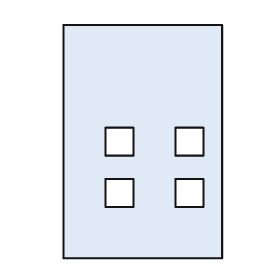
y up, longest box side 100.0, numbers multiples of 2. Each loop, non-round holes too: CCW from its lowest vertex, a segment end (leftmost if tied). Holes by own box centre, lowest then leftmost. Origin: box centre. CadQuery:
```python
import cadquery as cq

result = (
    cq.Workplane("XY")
    .moveTo(-34.0, -50.0)
    .lineTo(34.0, -50.0)
    .lineTo(34.0, 50.0)
    .lineTo(-34.0, 50.0)
    .close()
    .moveTo(-16.0, -28.0)
    .lineTo(-4.0, -28.0)
    .lineTo(-4.0, -16.0)
    .lineTo(-16.0, -16.0)
    .close()
    .moveTo(14.0, -28.0)
    .lineTo(26.0, -28.0)
    .lineTo(26.0, -16.0)
    .lineTo(14.0, -16.0)
    .close()
    .moveTo(-16.0, -6.0)
    .lineTo(-4.0, -6.0)
    .lineTo(-4.0, 6.0)
    .lineTo(-16.0, 6.0)
    .close()
    .moveTo(14.0, -6.0)
    .lineTo(26.0, -6.0)
    .lineTo(26.0, 6.0)
    .lineTo(14.0, 6.0)
    .close()
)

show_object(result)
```